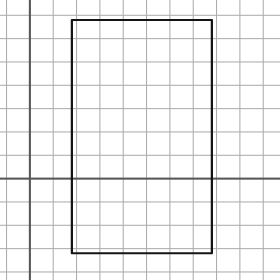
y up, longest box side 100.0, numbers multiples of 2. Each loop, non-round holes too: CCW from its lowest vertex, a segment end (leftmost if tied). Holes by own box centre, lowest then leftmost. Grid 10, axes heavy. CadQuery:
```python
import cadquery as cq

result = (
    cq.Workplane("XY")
    .moveTo(18.0, -32.0)
    .lineTo(78.0, -32.0)
    .lineTo(78.0, 68.0)
    .lineTo(18.0, 68.0)
    .close()
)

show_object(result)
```